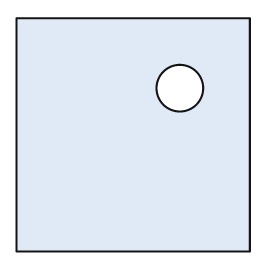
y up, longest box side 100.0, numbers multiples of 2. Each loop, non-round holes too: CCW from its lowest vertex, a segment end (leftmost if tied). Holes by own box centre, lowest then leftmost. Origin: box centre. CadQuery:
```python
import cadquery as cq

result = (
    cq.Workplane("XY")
    .moveTo(-50.0, -50.0)
    .lineTo(50.0, -50.0)
    .lineTo(50.0, 50.0)
    .lineTo(-50.0, 50.0)
    .close()
    .moveTo(20.0, 20.0)
    .circle(10.0)
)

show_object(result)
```